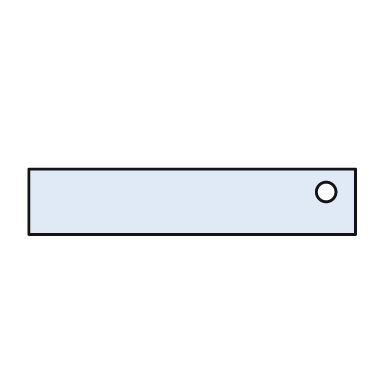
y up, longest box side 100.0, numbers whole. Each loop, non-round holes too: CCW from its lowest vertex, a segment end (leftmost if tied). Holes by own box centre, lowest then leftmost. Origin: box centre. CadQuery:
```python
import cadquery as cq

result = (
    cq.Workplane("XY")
    .moveTo(-50.0, -10.0)
    .lineTo(50.0, -10.0)
    .lineTo(50.0, 10.0)
    .lineTo(-50.0, 10.0)
    .close()
    .moveTo(41.0, 3.0)
    .circle(3.0)
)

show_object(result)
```